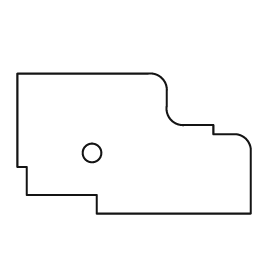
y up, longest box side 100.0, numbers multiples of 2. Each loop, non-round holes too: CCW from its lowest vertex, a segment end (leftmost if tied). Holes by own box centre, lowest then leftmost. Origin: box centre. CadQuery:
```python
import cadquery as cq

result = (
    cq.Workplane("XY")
    .moveTo(-16.0, -30.0)
    .lineTo(50.0, -30.0)
    .lineTo(50.0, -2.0)
    .threePointArc((48.0, 2.0), (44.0, 4.0))
    .lineTo(34.0, 4.0)
    .lineTo(34.0, 8.0)
    .lineTo(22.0, 8.0)
    .threePointArc((16.0, 10.0), (14.0, 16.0))
    .lineTo(14.0, 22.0)
    .threePointArc((12.0, 28.0), (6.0, 30.0))
    .lineTo(-50.0, 30.0)
    .lineTo(-50.0, -10.0)
    .lineTo(-46.0, -10.0)
    .lineTo(-46.0, -22.0)
    .lineTo(-16.0, -22.0)
    .close()
    .moveTo(-18.0, -4.0)
    .circle(4.0)
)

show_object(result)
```